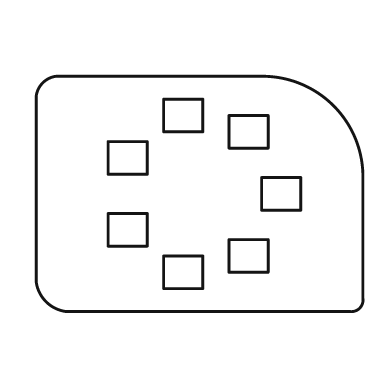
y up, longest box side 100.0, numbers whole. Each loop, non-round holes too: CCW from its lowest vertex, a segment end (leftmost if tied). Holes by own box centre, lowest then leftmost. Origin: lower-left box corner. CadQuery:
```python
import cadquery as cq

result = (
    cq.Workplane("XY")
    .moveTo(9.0, 0.0)
    .lineTo(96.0, 0.0)
    .threePointArc((99.0, 1.0), (100.0, 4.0))
    .lineTo(100.0, 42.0)
    .threePointArc((91.0, 63.0), (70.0, 72.0))
    .lineTo(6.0, 72.0)
    .threePointArc((2.0, 70.0), (0.0, 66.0))
    .lineTo(0.0, 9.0)
    .threePointArc((3.0, 3.0), (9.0, 0.0))
    .close()
    .moveTo(39.0, 7.0)
    .lineTo(51.0, 7.0)
    .lineTo(51.0, 17.0)
    .lineTo(39.0, 17.0)
    .close()
    .moveTo(59.0, 12.0)
    .lineTo(71.0, 12.0)
    .lineTo(71.0, 22.0)
    .lineTo(59.0, 22.0)
    .close()
    .moveTo(22.0, 20.0)
    .lineTo(34.0, 20.0)
    .lineTo(34.0, 30.0)
    .lineTo(22.0, 30.0)
    .close()
    .moveTo(69.0, 31.0)
    .lineTo(81.0, 31.0)
    .lineTo(81.0, 41.0)
    .lineTo(69.0, 41.0)
    .close()
    .moveTo(22.0, 42.0)
    .lineTo(34.0, 42.0)
    .lineTo(34.0, 52.0)
    .lineTo(22.0, 52.0)
    .close()
    .moveTo(59.0, 50.0)
    .lineTo(71.0, 50.0)
    .lineTo(71.0, 60.0)
    .lineTo(59.0, 60.0)
    .close()
    .moveTo(39.0, 55.0)
    .lineTo(51.0, 55.0)
    .lineTo(51.0, 65.0)
    .lineTo(39.0, 65.0)
    .close()
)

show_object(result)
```